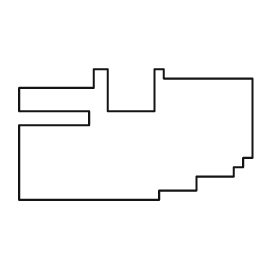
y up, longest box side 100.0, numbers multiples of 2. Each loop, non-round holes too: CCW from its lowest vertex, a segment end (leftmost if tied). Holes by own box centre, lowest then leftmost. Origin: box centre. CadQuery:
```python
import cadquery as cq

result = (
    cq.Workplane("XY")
    .moveTo(-50.0, -28.0)
    .lineTo(10.0, -28.0)
    .lineTo(10.0, -24.0)
    .lineTo(26.0, -24.0)
    .lineTo(26.0, -18.0)
    .lineTo(42.0, -18.0)
    .lineTo(42.0, -14.0)
    .lineTo(46.0, -14.0)
    .lineTo(46.0, -10.0)
    .lineTo(50.0, -10.0)
    .lineTo(50.0, 24.0)
    .lineTo(12.0, 24.0)
    .lineTo(12.0, 28.0)
    .lineTo(8.0, 28.0)
    .lineTo(8.0, 10.0)
    .lineTo(-12.0, 10.0)
    .lineTo(-12.0, 28.0)
    .lineTo(-18.0, 28.0)
    .lineTo(-18.0, 20.0)
    .lineTo(-50.0, 20.0)
    .lineTo(-50.0, 10.0)
    .lineTo(-20.0, 10.0)
    .lineTo(-20.0, 4.0)
    .lineTo(-50.0, 4.0)
    .close()
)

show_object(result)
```